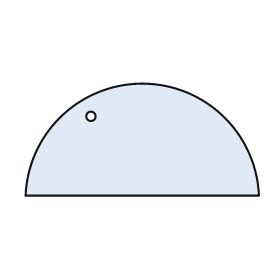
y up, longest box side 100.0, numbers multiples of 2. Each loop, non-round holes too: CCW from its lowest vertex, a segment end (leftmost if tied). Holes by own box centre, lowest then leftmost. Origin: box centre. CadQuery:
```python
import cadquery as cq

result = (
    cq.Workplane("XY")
    .moveTo(-50.0, -24.0)
    .lineTo(50.0, -24.0)
    .threePointArc((0.0, 24.0), (-50.0, -24.0))
    .close()
    .moveTo(-22.0, 10.0)
    .circle(2.0)
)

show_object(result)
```